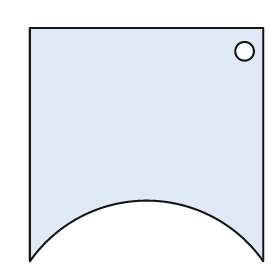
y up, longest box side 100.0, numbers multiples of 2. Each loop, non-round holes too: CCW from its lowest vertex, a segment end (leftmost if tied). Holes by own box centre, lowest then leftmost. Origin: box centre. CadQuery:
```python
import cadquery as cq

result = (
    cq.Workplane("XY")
    .moveTo(-50.0, -50.0)
    .threePointArc((0.0, -24.0), (50.0, -50.0))
    .lineTo(50.0, 50.0)
    .lineTo(-50.0, 50.0)
    .close()
    .moveTo(42.0, 40.0)
    .circle(4.0)
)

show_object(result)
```